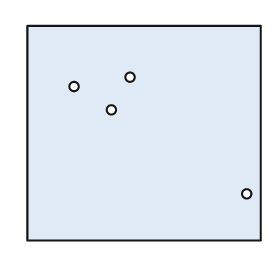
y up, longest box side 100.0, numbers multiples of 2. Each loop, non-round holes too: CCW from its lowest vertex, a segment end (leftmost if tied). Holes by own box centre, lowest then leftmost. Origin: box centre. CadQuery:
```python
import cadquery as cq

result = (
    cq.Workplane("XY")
    .moveTo(-50.0, -46.0)
    .lineTo(50.0, -46.0)
    .lineTo(50.0, 46.0)
    .lineTo(-50.0, 46.0)
    .close()
    .moveTo(44.0, -26.0)
    .circle(2.0)
    .moveTo(-14.0, 10.0)
    .circle(2.0)
    .moveTo(-30.0, 20.0)
    .circle(2.0)
    .moveTo(-6.0, 24.0)
    .circle(2.0)
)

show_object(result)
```